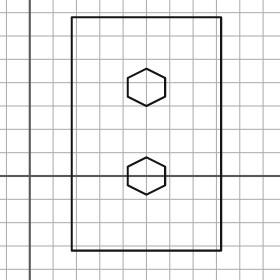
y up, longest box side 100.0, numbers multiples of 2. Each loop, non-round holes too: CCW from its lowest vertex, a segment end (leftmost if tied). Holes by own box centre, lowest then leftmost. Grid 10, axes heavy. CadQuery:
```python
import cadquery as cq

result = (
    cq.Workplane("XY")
    .moveTo(18.0, -32.0)
    .lineTo(82.0, -32.0)
    .lineTo(82.0, 68.0)
    .lineTo(18.0, 68.0)
    .close()
    .moveTo(50.0, -8.0)
    .lineTo(58.0, -4.0)
    .lineTo(58.0, 4.0)
    .lineTo(50.0, 8.0)
    .lineTo(42.0, 4.0)
    .lineTo(42.0, -4.0)
    .close()
    .moveTo(50.0, 30.0)
    .lineTo(58.0, 34.0)
    .lineTo(58.0, 42.0)
    .lineTo(50.0, 46.0)
    .lineTo(42.0, 42.0)
    .lineTo(42.0, 34.0)
    .close()
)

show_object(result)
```